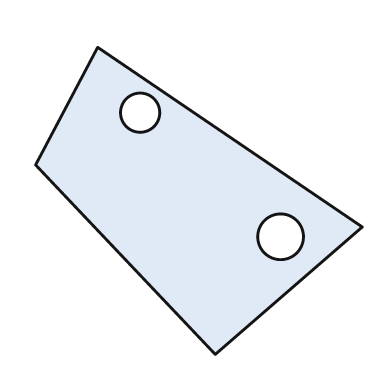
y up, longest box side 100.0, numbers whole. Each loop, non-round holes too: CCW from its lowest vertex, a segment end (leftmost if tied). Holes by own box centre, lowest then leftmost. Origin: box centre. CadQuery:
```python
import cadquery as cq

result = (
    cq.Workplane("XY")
    .moveTo(5.0, -47.0)
    .lineTo(50.0, -8.0)
    .lineTo(-31.0, 47.0)
    .lineTo(-50.0, 11.0)
    .close()
    .moveTo(25.0, -11.0)
    .circle(7.0)
    .moveTo(-18.0, 27.0)
    .circle(6.0)
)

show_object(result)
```